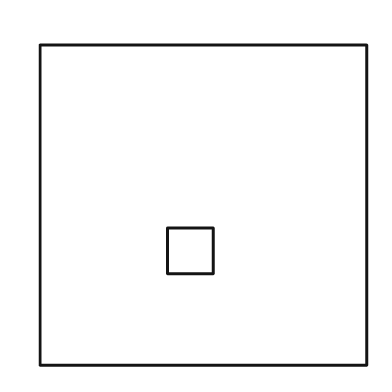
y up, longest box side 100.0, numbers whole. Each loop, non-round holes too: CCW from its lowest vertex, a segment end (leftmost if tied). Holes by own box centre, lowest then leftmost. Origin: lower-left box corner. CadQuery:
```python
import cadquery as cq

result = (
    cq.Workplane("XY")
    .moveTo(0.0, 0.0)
    .lineTo(100.0, 0.0)
    .lineTo(100.0, 98.0)
    .lineTo(0.0, 98.0)
    .close()
    .moveTo(39.0, 28.0)
    .lineTo(53.0, 28.0)
    .lineTo(53.0, 42.0)
    .lineTo(39.0, 42.0)
    .close()
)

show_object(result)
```